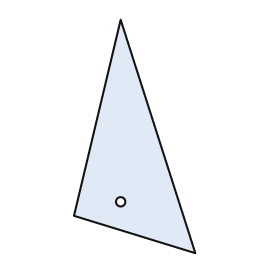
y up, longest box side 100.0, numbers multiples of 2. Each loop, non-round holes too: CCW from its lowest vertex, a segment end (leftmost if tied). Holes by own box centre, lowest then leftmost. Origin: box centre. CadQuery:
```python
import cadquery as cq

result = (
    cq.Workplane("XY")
    .moveTo(26.0, -50.0)
    .lineTo(-6.0, 50.0)
    .lineTo(-26.0, -34.0)
    .close()
    .moveTo(-6.0, -28.0)
    .circle(2.0)
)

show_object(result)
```